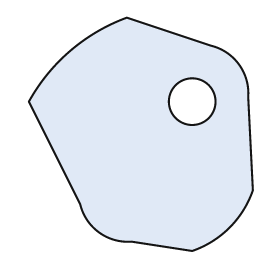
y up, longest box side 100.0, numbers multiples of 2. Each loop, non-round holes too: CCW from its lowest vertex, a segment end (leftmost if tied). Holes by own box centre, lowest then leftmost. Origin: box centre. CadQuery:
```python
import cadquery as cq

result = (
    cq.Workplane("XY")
    .moveTo(22.0, -50.0)
    .threePointArc((38.0, -40.0), (48.0, -24.0))
    .lineTo(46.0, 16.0)
    .threePointArc((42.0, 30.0), (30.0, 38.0))
    .lineTo(-6.0, 50.0)
    .threePointArc((-30.0, 36.0), (-48.0, 14.0))
    .lineTo(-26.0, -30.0)
    .threePointArc((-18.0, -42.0), (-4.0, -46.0))
    .close()
    .moveTo(22.0, 14.0)
    .circle(10.0)
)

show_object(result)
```